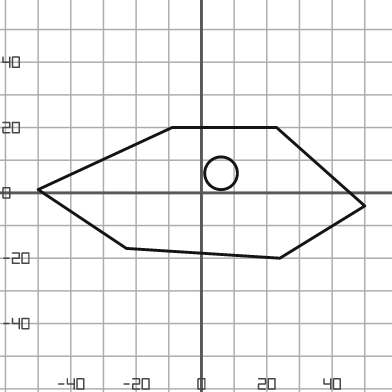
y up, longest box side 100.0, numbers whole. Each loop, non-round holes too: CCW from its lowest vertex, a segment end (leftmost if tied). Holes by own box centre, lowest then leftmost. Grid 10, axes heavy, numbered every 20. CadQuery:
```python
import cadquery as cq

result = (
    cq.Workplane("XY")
    .moveTo(24.0, -20.0)
    .lineTo(50.0, -4.0)
    .lineTo(23.0, 20.0)
    .lineTo(-9.0, 20.0)
    .lineTo(-50.0, 1.0)
    .lineTo(-23.0, -17.0)
    .close()
    .moveTo(6.0, 6.0)
    .circle(5.0)
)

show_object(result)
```